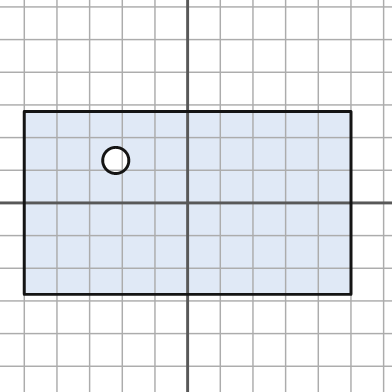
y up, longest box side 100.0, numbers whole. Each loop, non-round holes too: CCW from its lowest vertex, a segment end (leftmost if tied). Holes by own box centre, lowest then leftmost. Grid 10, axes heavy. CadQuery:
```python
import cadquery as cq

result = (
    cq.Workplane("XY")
    .moveTo(-50.0, -28.0)
    .lineTo(50.0, -28.0)
    .lineTo(50.0, 28.0)
    .lineTo(-50.0, 28.0)
    .close()
    .moveTo(-22.0, 13.0)
    .circle(4.0)
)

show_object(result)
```